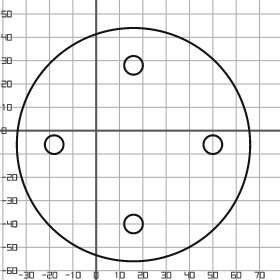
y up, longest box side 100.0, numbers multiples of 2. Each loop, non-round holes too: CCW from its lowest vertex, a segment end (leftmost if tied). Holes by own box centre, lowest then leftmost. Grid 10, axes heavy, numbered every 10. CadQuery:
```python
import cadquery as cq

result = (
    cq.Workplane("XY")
    .moveTo(16.0, -6.0)
    .circle(50.0)
    .moveTo(16.0, -40.0)
    .circle(4.0)
    .moveTo(-18.0, -6.0)
    .circle(4.0)
    .moveTo(50.0, -6.0)
    .circle(4.0)
    .moveTo(16.0, 28.0)
    .circle(4.0)
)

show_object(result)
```